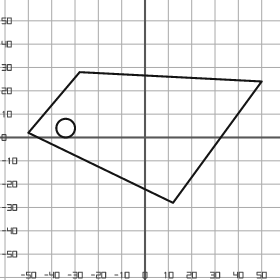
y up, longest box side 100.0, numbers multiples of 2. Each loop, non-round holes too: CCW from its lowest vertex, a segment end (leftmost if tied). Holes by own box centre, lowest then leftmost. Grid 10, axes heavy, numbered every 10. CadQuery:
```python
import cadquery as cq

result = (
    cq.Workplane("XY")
    .moveTo(12.0, -28.0)
    .lineTo(50.0, 24.0)
    .lineTo(-28.0, 28.0)
    .lineTo(-50.0, 2.0)
    .close()
    .moveTo(-34.0, 4.0)
    .circle(4.0)
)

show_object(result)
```